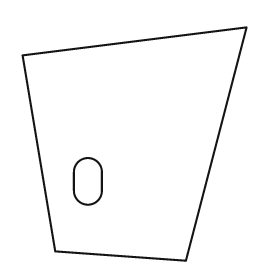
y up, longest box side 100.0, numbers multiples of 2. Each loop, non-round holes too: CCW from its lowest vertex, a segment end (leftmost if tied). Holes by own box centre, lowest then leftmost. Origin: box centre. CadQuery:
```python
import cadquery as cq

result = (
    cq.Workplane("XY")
    .moveTo(22.0, -50.0)
    .lineTo(48.0, 50.0)
    .lineTo(-48.0, 38.0)
    .lineTo(-34.0, -46.0)
    .close()
    .moveTo(-26.0, -20.0)
    .threePointArc((-20.0, -26.0), (-14.0, -20.0))
    .lineTo(-14.0, -12.0)
    .threePointArc((-20.0, -6.0), (-26.0, -12.0))
    .close()
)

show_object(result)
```